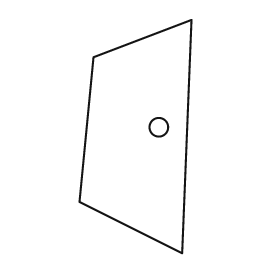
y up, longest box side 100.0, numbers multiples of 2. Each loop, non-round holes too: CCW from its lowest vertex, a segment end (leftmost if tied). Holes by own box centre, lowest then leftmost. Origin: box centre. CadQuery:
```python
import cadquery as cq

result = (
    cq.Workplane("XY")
    .moveTo(20.0, -50.0)
    .lineTo(24.0, 50.0)
    .lineTo(-18.0, 34.0)
    .lineTo(-24.0, -28.0)
    .close()
    .moveTo(10.0, 4.0)
    .circle(4.0)
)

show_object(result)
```